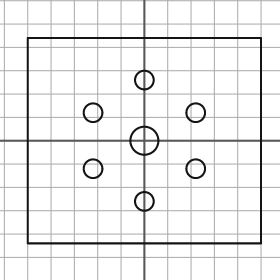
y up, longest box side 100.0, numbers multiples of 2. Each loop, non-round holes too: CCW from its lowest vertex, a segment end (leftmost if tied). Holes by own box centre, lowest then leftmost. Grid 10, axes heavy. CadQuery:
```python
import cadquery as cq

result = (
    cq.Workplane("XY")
    .moveTo(-50.0, -44.0)
    .lineTo(50.0, -44.0)
    .lineTo(50.0, 44.0)
    .lineTo(-50.0, 44.0)
    .close()
    .moveTo(0.0, -26.0)
    .circle(4.0)
    .moveTo(-22.0, -12.0)
    .circle(4.0)
    .moveTo(22.0, -12.0)
    .circle(4.0)
    .moveTo(0.0, 0.0)
    .circle(6.0)
    .moveTo(-22.0, 12.0)
    .circle(4.0)
    .moveTo(22.0, 12.0)
    .circle(4.0)
    .moveTo(0.0, 26.0)
    .circle(4.0)
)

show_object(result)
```